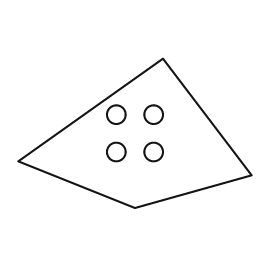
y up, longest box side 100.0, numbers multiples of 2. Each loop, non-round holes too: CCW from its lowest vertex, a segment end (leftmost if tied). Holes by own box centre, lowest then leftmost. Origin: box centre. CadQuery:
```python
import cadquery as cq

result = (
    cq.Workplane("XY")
    .moveTo(0.0, -32.0)
    .lineTo(50.0, -18.0)
    .lineTo(12.0, 32.0)
    .lineTo(-50.0, -12.0)
    .close()
    .moveTo(-8.0, -8.0)
    .circle(4.0)
    .moveTo(8.0, -8.0)
    .circle(4.0)
    .moveTo(-8.0, 8.0)
    .circle(4.0)
    .moveTo(8.0, 8.0)
    .circle(4.0)
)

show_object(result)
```